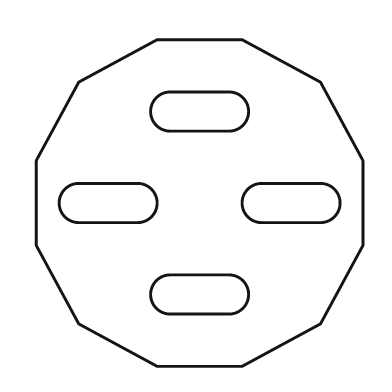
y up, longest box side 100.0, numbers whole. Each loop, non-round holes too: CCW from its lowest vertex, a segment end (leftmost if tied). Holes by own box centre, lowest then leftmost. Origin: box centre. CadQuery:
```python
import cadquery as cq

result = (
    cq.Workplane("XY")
    .moveTo(-13.0, -50.0)
    .lineTo(13.0, -50.0)
    .lineTo(37.0, -37.0)
    .lineTo(50.0, -13.0)
    .lineTo(50.0, 13.0)
    .lineTo(37.0, 37.0)
    .lineTo(13.0, 50.0)
    .lineTo(-13.0, 50.0)
    .lineTo(-37.0, 37.0)
    .lineTo(-50.0, 13.0)
    .lineTo(-50.0, -13.0)
    .lineTo(-37.0, -37.0)
    .close()
    .moveTo(-9.0, -34.0)
    .lineTo(9.0, -34.0)
    .threePointArc((15.0, -28.0), (9.0, -22.0))
    .lineTo(-9.0, -22.0)
    .threePointArc((-15.0, -28.0), (-9.0, -34.0))
    .close()
    .moveTo(-37.0, -6.0)
    .lineTo(-19.0, -6.0)
    .threePointArc((-13.0, 0.0), (-19.0, 6.0))
    .lineTo(-37.0, 6.0)
    .threePointArc((-43.0, 0.0), (-37.0, -6.0))
    .close()
    .moveTo(19.0, -6.0)
    .lineTo(37.0, -6.0)
    .threePointArc((43.0, 0.0), (37.0, 6.0))
    .lineTo(19.0, 6.0)
    .threePointArc((13.0, 0.0), (19.0, -6.0))
    .close()
    .moveTo(-9.0, 22.0)
    .lineTo(9.0, 22.0)
    .threePointArc((15.0, 28.0), (9.0, 34.0))
    .lineTo(-9.0, 34.0)
    .threePointArc((-15.0, 28.0), (-9.0, 22.0))
    .close()
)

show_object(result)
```